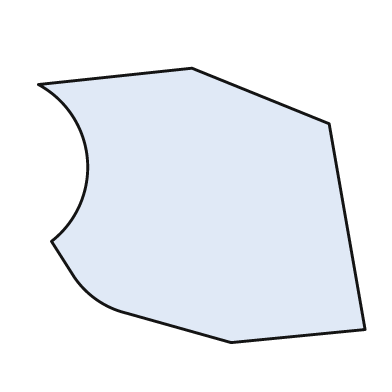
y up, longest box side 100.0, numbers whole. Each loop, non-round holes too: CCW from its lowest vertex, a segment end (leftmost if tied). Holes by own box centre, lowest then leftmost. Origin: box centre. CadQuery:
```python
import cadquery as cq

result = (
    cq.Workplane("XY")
    .moveTo(9.0, -42.0)
    .lineTo(50.0, -38.0)
    .lineTo(39.0, 25.0)
    .lineTo(-3.0, 42.0)
    .lineTo(-50.0, 37.0)
    .threePointArc((-35.0, 14.0), (-46.0, -11.0))
    .lineTo(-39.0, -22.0)
    .threePointArc((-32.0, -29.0), (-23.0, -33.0))
    .close()
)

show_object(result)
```